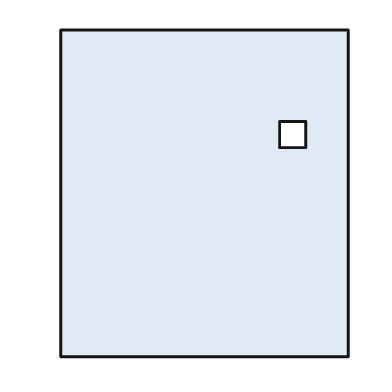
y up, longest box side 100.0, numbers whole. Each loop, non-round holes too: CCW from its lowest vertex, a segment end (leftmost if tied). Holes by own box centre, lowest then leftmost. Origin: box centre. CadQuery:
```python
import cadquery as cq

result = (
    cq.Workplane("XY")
    .moveTo(-44.0, -50.0)
    .lineTo(44.0, -50.0)
    .lineTo(44.0, 50.0)
    .lineTo(-44.0, 50.0)
    .close()
    .moveTo(23.0, 14.0)
    .lineTo(31.0, 14.0)
    .lineTo(31.0, 22.0)
    .lineTo(23.0, 22.0)
    .close()
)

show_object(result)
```